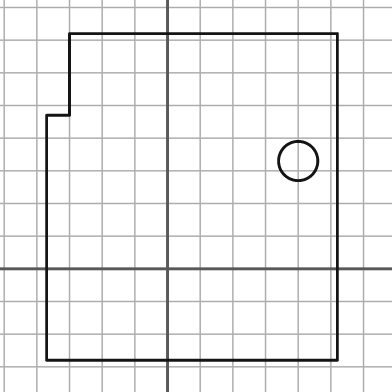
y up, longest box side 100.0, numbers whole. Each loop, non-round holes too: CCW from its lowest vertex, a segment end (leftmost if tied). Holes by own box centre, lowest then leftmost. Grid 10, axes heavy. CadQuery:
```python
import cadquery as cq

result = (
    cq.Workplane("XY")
    .moveTo(-37.0, -28.0)
    .lineTo(52.0, -28.0)
    .lineTo(52.0, 72.0)
    .lineTo(-30.0, 72.0)
    .lineTo(-30.0, 47.0)
    .lineTo(-37.0, 47.0)
    .close()
    .moveTo(40.0, 33.0)
    .circle(6.0)
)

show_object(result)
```